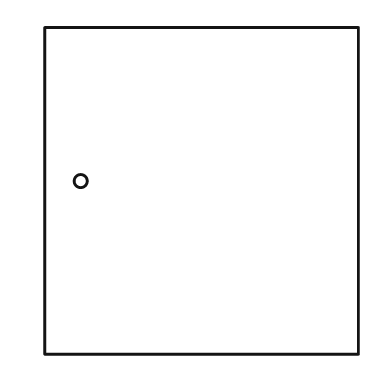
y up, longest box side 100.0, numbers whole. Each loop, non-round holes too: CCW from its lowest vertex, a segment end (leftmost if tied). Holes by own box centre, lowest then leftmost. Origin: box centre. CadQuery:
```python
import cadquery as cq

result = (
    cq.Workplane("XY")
    .moveTo(-48.0, -50.0)
    .lineTo(48.0, -50.0)
    .lineTo(48.0, 50.0)
    .lineTo(-48.0, 50.0)
    .close()
    .moveTo(-37.0, 3.0)
    .circle(2.0)
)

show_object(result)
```